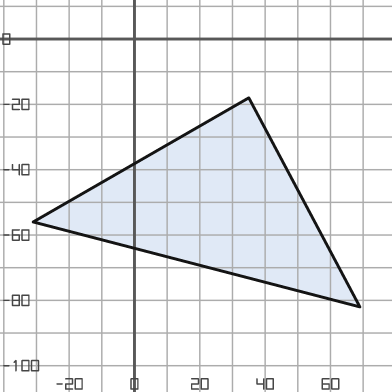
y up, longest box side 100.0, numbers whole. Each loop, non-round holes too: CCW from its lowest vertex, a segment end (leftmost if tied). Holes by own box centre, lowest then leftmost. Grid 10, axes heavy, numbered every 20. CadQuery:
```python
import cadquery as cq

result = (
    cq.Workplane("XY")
    .moveTo(69.0, -82.0)
    .lineTo(35.0, -18.0)
    .lineTo(-31.0, -56.0)
    .close()
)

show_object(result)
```